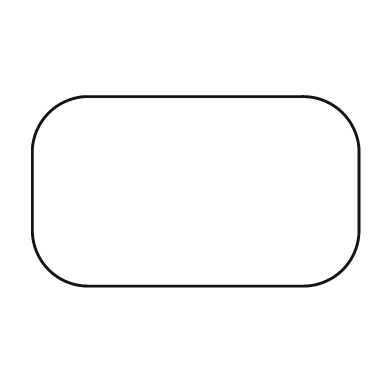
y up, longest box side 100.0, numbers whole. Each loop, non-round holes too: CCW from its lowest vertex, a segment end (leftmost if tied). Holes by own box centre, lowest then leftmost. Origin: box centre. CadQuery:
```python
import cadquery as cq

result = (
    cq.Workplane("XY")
    .moveTo(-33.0, -29.0)
    .lineTo(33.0, -29.0)
    .threePointArc((45.0, -24.0), (50.0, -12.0))
    .lineTo(50.0, 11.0)
    .threePointArc((45.0, 24.0), (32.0, 29.0))
    .lineTo(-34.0, 29.0)
    .threePointArc((-45.0, 24.0), (-50.0, 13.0))
    .lineTo(-50.0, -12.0)
    .threePointArc((-45.0, -24.0), (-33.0, -29.0))
    .close()
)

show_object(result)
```